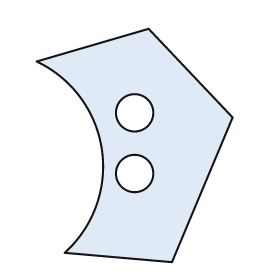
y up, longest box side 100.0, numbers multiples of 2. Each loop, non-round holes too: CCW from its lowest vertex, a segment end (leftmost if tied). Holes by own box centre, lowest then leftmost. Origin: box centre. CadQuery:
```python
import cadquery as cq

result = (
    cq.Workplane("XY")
    .moveTo(16.0, -50.0)
    .lineTo(42.0, 12.0)
    .lineTo(6.0, 50.0)
    .lineTo(-42.0, 36.0)
    .threePointArc((-14.0, -2.0), (-30.0, -46.0))
    .close()
    .moveTo(0.0, -12.0)
    .circle(8.0)
    .moveTo(0.0, 14.0)
    .circle(8.0)
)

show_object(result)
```